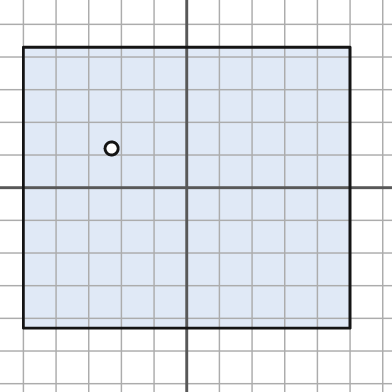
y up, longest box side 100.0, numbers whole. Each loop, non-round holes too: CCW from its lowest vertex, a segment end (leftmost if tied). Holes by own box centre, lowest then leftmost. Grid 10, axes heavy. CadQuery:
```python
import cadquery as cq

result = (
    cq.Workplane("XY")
    .moveTo(-50.0, -43.0)
    .lineTo(50.0, -43.0)
    .lineTo(50.0, 43.0)
    .lineTo(-50.0, 43.0)
    .close()
    .moveTo(-23.0, 12.0)
    .circle(2.0)
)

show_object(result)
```